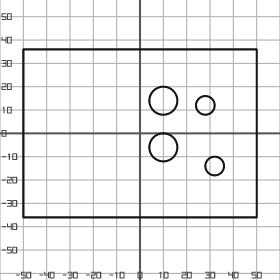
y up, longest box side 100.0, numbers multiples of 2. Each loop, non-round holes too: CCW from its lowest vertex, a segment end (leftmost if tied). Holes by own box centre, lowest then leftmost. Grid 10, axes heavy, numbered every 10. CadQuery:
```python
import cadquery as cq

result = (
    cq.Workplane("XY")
    .moveTo(-50.0, -36.0)
    .lineTo(50.0, -36.0)
    .lineTo(50.0, 36.0)
    .lineTo(-50.0, 36.0)
    .close()
    .moveTo(32.0, -14.0)
    .circle(4.0)
    .moveTo(10.0, -6.0)
    .circle(6.0)
    .moveTo(28.0, 12.0)
    .circle(4.0)
    .moveTo(10.0, 14.0)
    .circle(6.0)
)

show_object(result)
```